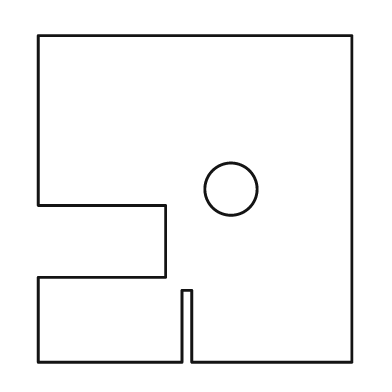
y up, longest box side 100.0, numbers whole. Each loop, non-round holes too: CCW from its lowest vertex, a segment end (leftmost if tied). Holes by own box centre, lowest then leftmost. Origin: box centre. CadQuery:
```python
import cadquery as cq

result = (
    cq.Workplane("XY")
    .moveTo(-48.0, -50.0)
    .lineTo(-4.0, -50.0)
    .lineTo(-4.0, -28.0)
    .lineTo(-1.0, -28.0)
    .lineTo(-1.0, -50.0)
    .lineTo(48.0, -50.0)
    .lineTo(48.0, 50.0)
    .lineTo(-48.0, 50.0)
    .lineTo(-48.0, -2.0)
    .lineTo(-9.0, -2.0)
    .lineTo(-9.0, -24.0)
    .lineTo(-48.0, -24.0)
    .close()
    .moveTo(11.0, 3.0)
    .circle(8.0)
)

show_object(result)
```